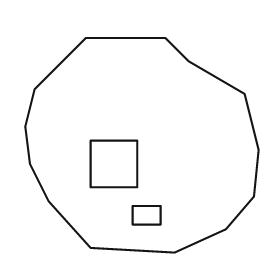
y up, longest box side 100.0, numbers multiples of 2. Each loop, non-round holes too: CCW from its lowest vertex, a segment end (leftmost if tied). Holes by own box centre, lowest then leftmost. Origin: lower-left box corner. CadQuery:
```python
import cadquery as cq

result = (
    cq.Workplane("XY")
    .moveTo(64.0, 0.0)
    .lineTo(86.0, 10.0)
    .lineTo(98.0, 24.0)
    .lineTo(100.0, 44.0)
    .lineTo(94.0, 68.0)
    .lineTo(70.0, 82.0)
    .lineTo(60.0, 92.0)
    .lineTo(26.0, 92.0)
    .lineTo(4.0, 70.0)
    .lineTo(0.0, 54.0)
    .lineTo(2.0, 38.0)
    .lineTo(10.0, 22.0)
    .lineTo(28.0, 2.0)
    .close()
    .moveTo(46.0, 12.0)
    .lineTo(58.0, 12.0)
    .lineTo(58.0, 20.0)
    .lineTo(46.0, 20.0)
    .close()
    .moveTo(28.0, 28.0)
    .lineTo(48.0, 28.0)
    .lineTo(48.0, 48.0)
    .lineTo(28.0, 48.0)
    .close()
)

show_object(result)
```